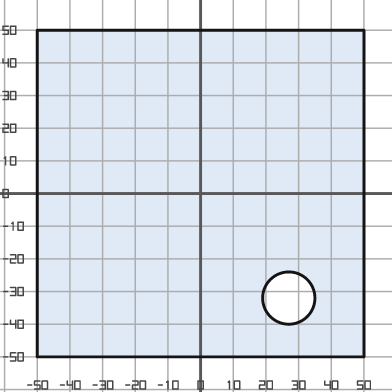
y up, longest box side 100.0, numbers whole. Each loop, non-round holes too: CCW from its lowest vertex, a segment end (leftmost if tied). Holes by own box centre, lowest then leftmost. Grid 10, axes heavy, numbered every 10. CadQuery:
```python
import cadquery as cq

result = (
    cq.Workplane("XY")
    .moveTo(-50.0, -50.0)
    .lineTo(50.0, -50.0)
    .lineTo(50.0, 50.0)
    .lineTo(-50.0, 50.0)
    .close()
    .moveTo(27.0, -32.0)
    .circle(8.0)
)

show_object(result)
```